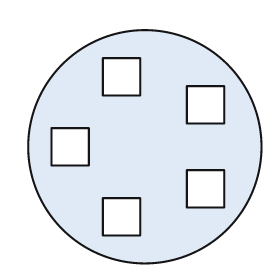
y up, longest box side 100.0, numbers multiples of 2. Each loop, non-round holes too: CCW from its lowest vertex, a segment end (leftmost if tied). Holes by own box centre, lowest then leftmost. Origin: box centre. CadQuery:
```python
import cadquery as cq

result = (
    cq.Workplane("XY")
    .moveTo(0.0, 0.0)
    .circle(50.0)
    .moveTo(-18.0, -38.0)
    .lineTo(-2.0, -38.0)
    .lineTo(-2.0, -22.0)
    .lineTo(-18.0, -22.0)
    .close()
    .moveTo(18.0, -26.0)
    .lineTo(34.0, -26.0)
    .lineTo(34.0, -10.0)
    .lineTo(18.0, -10.0)
    .close()
    .moveTo(-40.0, -8.0)
    .lineTo(-24.0, -8.0)
    .lineTo(-24.0, 8.0)
    .lineTo(-40.0, 8.0)
    .close()
    .moveTo(18.0, 10.0)
    .lineTo(34.0, 10.0)
    .lineTo(34.0, 26.0)
    .lineTo(18.0, 26.0)
    .close()
    .moveTo(-18.0, 22.0)
    .lineTo(-2.0, 22.0)
    .lineTo(-2.0, 38.0)
    .lineTo(-18.0, 38.0)
    .close()
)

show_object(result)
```